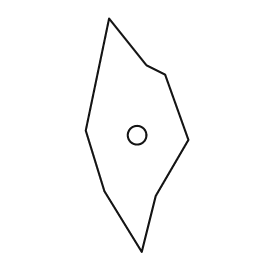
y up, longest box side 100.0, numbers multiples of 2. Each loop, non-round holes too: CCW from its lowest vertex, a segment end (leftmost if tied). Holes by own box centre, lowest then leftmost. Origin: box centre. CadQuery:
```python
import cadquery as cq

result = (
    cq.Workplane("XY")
    .moveTo(2.0, -50.0)
    .lineTo(8.0, -26.0)
    .lineTo(22.0, -2.0)
    .lineTo(12.0, 26.0)
    .lineTo(4.0, 30.0)
    .lineTo(-12.0, 50.0)
    .lineTo(-22.0, 2.0)
    .lineTo(-14.0, -24.0)
    .close()
    .moveTo(0.0, 0.0)
    .circle(4.0)
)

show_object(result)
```